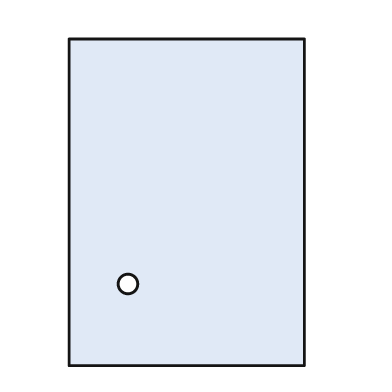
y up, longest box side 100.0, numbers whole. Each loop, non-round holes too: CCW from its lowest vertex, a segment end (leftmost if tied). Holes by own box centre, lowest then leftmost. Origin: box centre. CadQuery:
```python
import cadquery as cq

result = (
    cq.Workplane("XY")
    .moveTo(-36.0, -50.0)
    .lineTo(36.0, -50.0)
    .lineTo(36.0, 50.0)
    .lineTo(-36.0, 50.0)
    .close()
    .moveTo(-18.0, -25.0)
    .circle(3.0)
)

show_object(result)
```